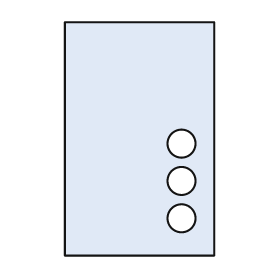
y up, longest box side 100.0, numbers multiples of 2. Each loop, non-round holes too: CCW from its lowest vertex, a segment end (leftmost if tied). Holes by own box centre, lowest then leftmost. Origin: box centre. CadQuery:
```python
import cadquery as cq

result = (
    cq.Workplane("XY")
    .moveTo(-32.0, -50.0)
    .lineTo(32.0, -50.0)
    .lineTo(32.0, 50.0)
    .lineTo(-32.0, 50.0)
    .close()
    .moveTo(18.0, -34.0)
    .circle(6.0)
    .moveTo(18.0, -18.0)
    .circle(6.0)
    .moveTo(18.0, -2.0)
    .circle(6.0)
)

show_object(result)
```